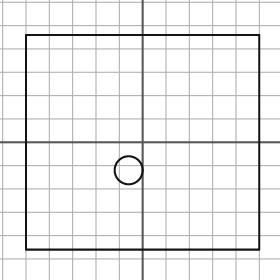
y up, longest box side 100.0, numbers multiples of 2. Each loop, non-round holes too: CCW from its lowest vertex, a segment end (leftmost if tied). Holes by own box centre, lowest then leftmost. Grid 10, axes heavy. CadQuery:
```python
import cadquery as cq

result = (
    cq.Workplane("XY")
    .moveTo(-50.0, -46.0)
    .lineTo(50.0, -46.0)
    .lineTo(50.0, 46.0)
    .lineTo(-50.0, 46.0)
    .close()
    .moveTo(-6.0, -12.0)
    .circle(6.0)
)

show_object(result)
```